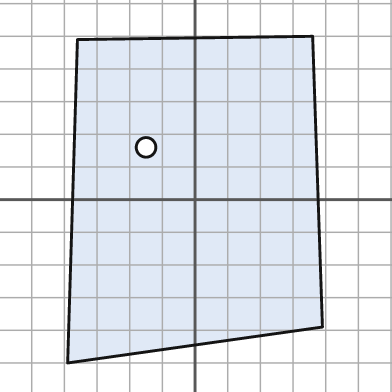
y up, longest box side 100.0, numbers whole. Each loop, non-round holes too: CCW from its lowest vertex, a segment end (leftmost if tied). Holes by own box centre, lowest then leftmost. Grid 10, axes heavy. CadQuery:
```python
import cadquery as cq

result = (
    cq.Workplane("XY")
    .moveTo(-39.0, -50.0)
    .lineTo(39.0, -39.0)
    .lineTo(36.0, 50.0)
    .lineTo(-36.0, 49.0)
    .close()
    .moveTo(-15.0, 16.0)
    .circle(3.0)
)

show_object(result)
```